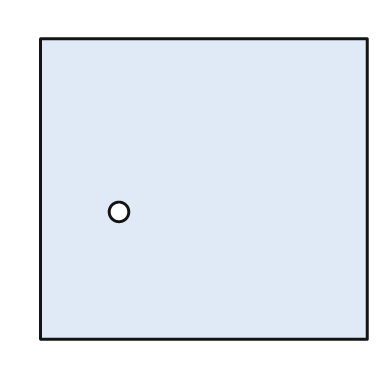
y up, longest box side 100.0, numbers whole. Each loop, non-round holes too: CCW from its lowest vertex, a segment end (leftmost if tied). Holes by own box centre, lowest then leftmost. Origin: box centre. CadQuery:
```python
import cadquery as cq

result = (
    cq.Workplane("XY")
    .moveTo(-50.0, -46.0)
    .lineTo(50.0, -46.0)
    .lineTo(50.0, 46.0)
    .lineTo(-50.0, 46.0)
    .close()
    .moveTo(-26.0, -7.0)
    .circle(3.0)
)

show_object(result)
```